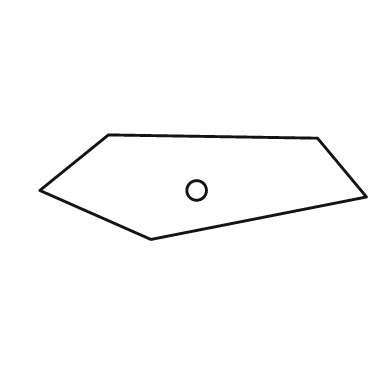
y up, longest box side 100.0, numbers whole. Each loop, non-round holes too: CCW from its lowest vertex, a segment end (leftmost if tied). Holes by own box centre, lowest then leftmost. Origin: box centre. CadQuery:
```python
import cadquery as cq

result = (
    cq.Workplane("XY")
    .moveTo(-16.0, -16.0)
    .lineTo(50.0, -3.0)
    .lineTo(35.0, 15.0)
    .lineTo(-29.0, 16.0)
    .lineTo(-50.0, -1.0)
    .close()
    .moveTo(-2.0, -1.0)
    .circle(3.0)
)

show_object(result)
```